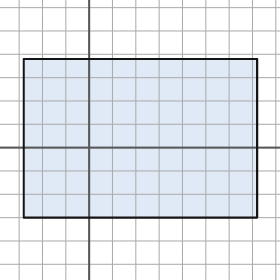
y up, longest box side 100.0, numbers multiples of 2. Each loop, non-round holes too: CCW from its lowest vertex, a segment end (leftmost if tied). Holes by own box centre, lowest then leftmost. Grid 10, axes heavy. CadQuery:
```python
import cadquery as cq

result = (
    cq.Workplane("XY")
    .moveTo(-28.0, -30.0)
    .lineTo(72.0, -30.0)
    .lineTo(72.0, 38.0)
    .lineTo(-28.0, 38.0)
    .close()
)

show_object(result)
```